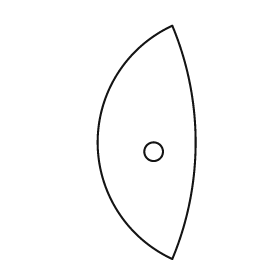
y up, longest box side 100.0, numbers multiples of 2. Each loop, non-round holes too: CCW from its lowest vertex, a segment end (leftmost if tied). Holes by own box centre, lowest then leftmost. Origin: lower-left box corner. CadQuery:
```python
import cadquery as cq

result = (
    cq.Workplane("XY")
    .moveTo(32.0, 0.0)
    .threePointArc((42.0, 50.0), (32.0, 100.0))
    .threePointArc((0.0, 50.0), (32.0, 0.0))
    .close()
    .moveTo(24.0, 46.0)
    .circle(4.0)
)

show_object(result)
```